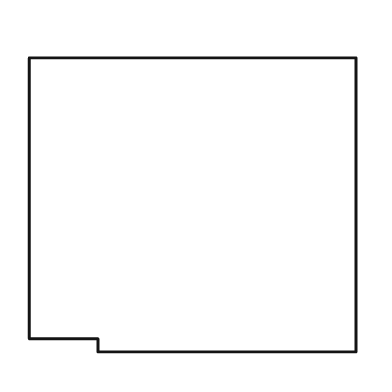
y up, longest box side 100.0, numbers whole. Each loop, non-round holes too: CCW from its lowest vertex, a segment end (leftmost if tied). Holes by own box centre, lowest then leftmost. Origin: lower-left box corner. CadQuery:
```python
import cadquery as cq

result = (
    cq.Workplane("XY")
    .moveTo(21.0, 0.0)
    .lineTo(100.0, 0.0)
    .lineTo(100.0, 90.0)
    .lineTo(0.0, 90.0)
    .lineTo(0.0, 4.0)
    .lineTo(21.0, 4.0)
    .close()
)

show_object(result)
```